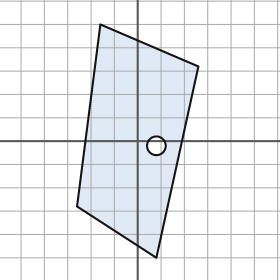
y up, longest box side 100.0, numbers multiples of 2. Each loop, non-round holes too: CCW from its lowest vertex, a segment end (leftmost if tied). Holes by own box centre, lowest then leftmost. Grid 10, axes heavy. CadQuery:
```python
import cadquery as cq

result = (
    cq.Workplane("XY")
    .moveTo(8.0, -50.0)
    .lineTo(26.0, 32.0)
    .lineTo(-16.0, 50.0)
    .lineTo(-26.0, -28.0)
    .close()
    .moveTo(8.0, -2.0)
    .circle(4.0)
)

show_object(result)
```